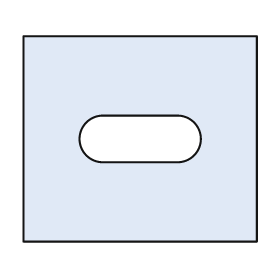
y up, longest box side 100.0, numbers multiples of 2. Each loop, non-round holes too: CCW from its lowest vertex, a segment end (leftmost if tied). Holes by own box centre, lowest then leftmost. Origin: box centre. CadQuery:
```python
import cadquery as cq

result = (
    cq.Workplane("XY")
    .moveTo(-50.0, -44.0)
    .lineTo(50.0, -44.0)
    .lineTo(50.0, 44.0)
    .lineTo(-50.0, 44.0)
    .close()
    .moveTo(-16.0, -10.0)
    .lineTo(16.0, -10.0)
    .threePointArc((26.0, 0.0), (16.0, 10.0))
    .lineTo(-16.0, 10.0)
    .threePointArc((-26.0, 0.0), (-16.0, -10.0))
    .close()
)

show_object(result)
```